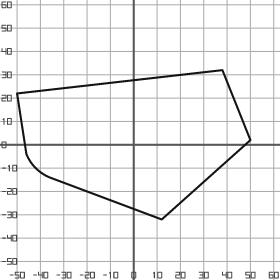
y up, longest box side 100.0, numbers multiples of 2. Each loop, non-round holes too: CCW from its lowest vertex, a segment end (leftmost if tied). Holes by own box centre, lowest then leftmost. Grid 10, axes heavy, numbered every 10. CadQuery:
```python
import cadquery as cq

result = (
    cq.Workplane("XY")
    .moveTo(12.0, -32.0)
    .lineTo(50.0, 2.0)
    .lineTo(38.0, 32.0)
    .lineTo(-50.0, 22.0)
    .lineTo(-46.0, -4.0)
    .threePointArc((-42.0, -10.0), (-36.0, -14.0))
    .close()
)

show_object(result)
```